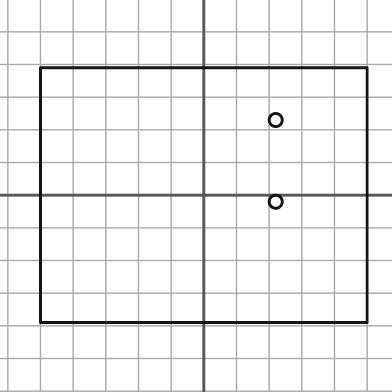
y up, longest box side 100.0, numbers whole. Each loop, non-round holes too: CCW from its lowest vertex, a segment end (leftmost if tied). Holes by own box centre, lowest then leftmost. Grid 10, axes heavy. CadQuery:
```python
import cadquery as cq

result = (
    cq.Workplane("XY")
    .moveTo(-50.0, -39.0)
    .lineTo(50.0, -39.0)
    .lineTo(50.0, 39.0)
    .lineTo(-50.0, 39.0)
    .close()
    .moveTo(22.0, -2.0)
    .circle(2.0)
    .moveTo(22.0, 23.0)
    .circle(2.0)
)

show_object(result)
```